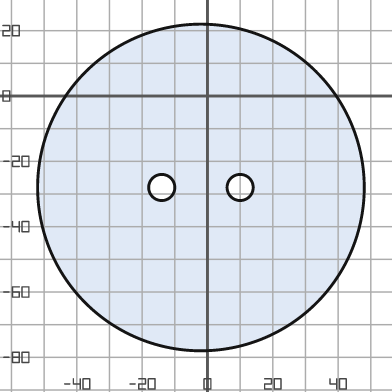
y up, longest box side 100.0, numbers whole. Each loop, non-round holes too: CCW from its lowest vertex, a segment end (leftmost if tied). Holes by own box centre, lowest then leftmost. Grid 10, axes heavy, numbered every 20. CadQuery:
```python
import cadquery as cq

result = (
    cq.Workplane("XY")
    .moveTo(-2.0, -28.0)
    .circle(50.0)
    .moveTo(-14.0, -28.0)
    .circle(4.0)
    .moveTo(10.0, -28.0)
    .circle(4.0)
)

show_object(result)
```